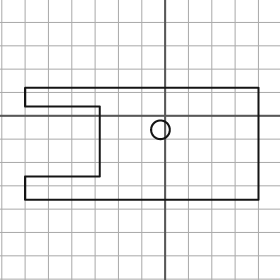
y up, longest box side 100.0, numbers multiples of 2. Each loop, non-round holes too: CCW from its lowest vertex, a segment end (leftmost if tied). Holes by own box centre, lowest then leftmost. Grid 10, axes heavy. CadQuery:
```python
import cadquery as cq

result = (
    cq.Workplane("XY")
    .moveTo(-60.0, -36.0)
    .lineTo(40.0, -36.0)
    .lineTo(40.0, 12.0)
    .lineTo(-60.0, 12.0)
    .lineTo(-60.0, 4.0)
    .lineTo(-28.0, 4.0)
    .lineTo(-28.0, -26.0)
    .lineTo(-60.0, -26.0)
    .close()
    .moveTo(-2.0, -6.0)
    .circle(4.0)
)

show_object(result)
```